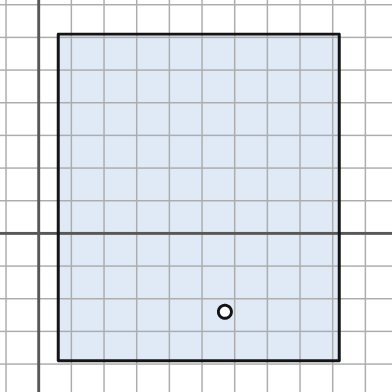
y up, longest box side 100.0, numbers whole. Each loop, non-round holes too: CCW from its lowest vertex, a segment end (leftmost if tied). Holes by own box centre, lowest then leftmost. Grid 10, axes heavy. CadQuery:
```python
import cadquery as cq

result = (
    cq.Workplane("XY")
    .moveTo(6.0, -39.0)
    .lineTo(92.0, -39.0)
    .lineTo(92.0, 61.0)
    .lineTo(6.0, 61.0)
    .close()
    .moveTo(57.0, -24.0)
    .circle(2.0)
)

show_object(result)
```